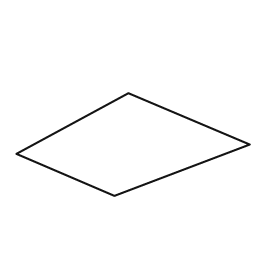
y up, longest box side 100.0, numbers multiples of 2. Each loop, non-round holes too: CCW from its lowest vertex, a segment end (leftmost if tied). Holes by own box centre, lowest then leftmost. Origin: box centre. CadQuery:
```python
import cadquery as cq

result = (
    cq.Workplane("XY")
    .moveTo(-8.0, -22.0)
    .lineTo(50.0, 0.0)
    .lineTo(-2.0, 22.0)
    .lineTo(-50.0, -4.0)
    .close()
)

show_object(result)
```